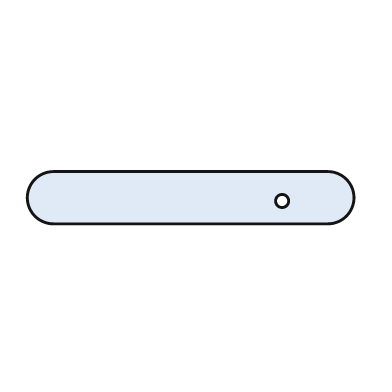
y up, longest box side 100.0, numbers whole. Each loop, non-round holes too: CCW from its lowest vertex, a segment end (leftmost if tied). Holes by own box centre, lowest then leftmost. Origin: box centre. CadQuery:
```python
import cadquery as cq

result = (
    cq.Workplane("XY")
    .moveTo(-42.0, -8.0)
    .lineTo(42.0, -8.0)
    .threePointArc((50.0, 0.0), (42.0, 8.0))
    .lineTo(-42.0, 8.0)
    .threePointArc((-50.0, 0.0), (-42.0, -8.0))
    .close()
    .moveTo(28.0, -1.0)
    .circle(2.0)
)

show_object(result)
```